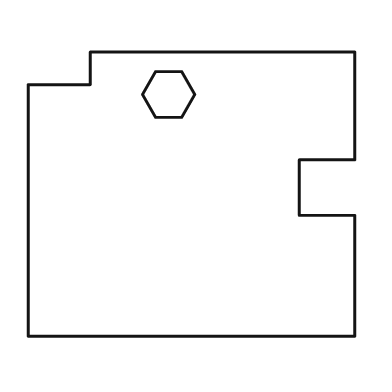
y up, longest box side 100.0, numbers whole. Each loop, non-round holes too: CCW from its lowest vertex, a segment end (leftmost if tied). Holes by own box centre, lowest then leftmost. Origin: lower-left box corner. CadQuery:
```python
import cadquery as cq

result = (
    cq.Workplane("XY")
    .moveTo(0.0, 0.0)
    .lineTo(100.0, 0.0)
    .lineTo(100.0, 37.0)
    .lineTo(83.0, 37.0)
    .lineTo(83.0, 54.0)
    .lineTo(100.0, 54.0)
    .lineTo(100.0, 87.0)
    .lineTo(19.0, 87.0)
    .lineTo(19.0, 77.0)
    .lineTo(0.0, 77.0)
    .close()
    .moveTo(39.0, 67.0)
    .lineTo(47.0, 67.0)
    .lineTo(51.0, 74.0)
    .lineTo(47.0, 81.0)
    .lineTo(39.0, 81.0)
    .lineTo(35.0, 74.0)
    .close()
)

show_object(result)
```